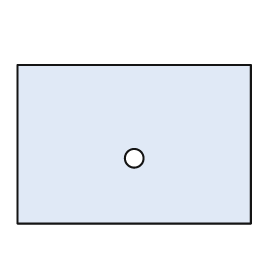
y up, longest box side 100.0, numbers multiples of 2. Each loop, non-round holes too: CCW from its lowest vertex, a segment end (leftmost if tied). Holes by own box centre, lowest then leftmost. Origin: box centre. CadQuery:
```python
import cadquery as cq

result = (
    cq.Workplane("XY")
    .moveTo(-50.0, -34.0)
    .lineTo(50.0, -34.0)
    .lineTo(50.0, 34.0)
    .lineTo(-50.0, 34.0)
    .close()
    .moveTo(0.0, -6.0)
    .circle(4.0)
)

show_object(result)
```